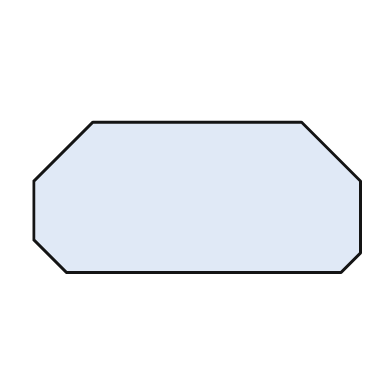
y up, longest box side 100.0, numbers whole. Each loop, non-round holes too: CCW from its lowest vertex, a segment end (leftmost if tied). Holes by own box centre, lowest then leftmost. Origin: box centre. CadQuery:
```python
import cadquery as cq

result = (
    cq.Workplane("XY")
    .moveTo(-40.0, -23.0)
    .lineTo(44.0, -23.0)
    .lineTo(50.0, -17.0)
    .lineTo(50.0, 5.0)
    .lineTo(32.0, 23.0)
    .lineTo(-32.0, 23.0)
    .lineTo(-50.0, 5.0)
    .lineTo(-50.0, -13.0)
    .close()
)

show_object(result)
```